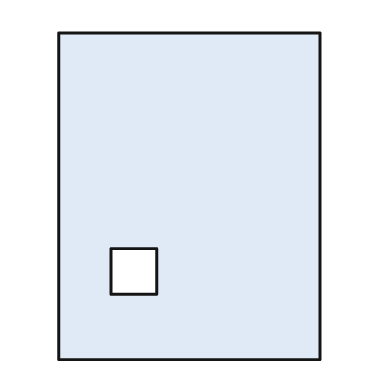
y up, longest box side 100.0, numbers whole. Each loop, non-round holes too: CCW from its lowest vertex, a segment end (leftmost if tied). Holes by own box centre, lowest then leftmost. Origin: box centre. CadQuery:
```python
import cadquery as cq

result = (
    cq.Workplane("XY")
    .moveTo(-40.0, -50.0)
    .lineTo(40.0, -50.0)
    .lineTo(40.0, 50.0)
    .lineTo(-40.0, 50.0)
    .close()
    .moveTo(-24.0, -30.0)
    .lineTo(-10.0, -30.0)
    .lineTo(-10.0, -16.0)
    .lineTo(-24.0, -16.0)
    .close()
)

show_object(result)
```